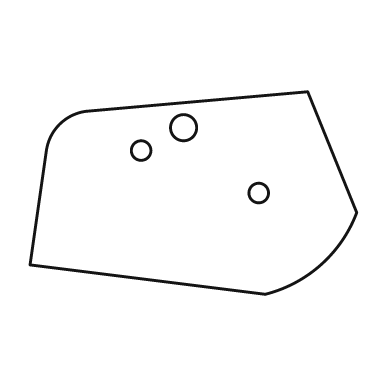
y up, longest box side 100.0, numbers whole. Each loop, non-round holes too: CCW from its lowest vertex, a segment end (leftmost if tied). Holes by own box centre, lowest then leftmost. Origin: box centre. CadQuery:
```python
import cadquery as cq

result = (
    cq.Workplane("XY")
    .moveTo(22.0, -31.0)
    .threePointArc((39.0, -22.0), (50.0, -6.0))
    .lineTo(35.0, 31.0)
    .lineTo(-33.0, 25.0)
    .threePointArc((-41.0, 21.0), (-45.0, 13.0))
    .lineTo(-50.0, -22.0)
    .close()
    .moveTo(20.0, 0.0)
    .circle(3.0)
    .moveTo(-16.0, 13.0)
    .circle(3.0)
    .moveTo(-3.0, 20.0)
    .circle(4.0)
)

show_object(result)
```